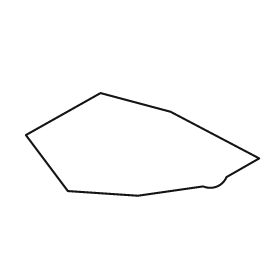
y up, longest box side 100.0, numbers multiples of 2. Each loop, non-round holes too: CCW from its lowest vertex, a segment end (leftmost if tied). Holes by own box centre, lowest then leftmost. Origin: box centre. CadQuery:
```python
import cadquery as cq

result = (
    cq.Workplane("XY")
    .moveTo(-2.0, -22.0)
    .lineTo(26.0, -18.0)
    .threePointArc((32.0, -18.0), (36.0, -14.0))
    .lineTo(50.0, -6.0)
    .lineTo(12.0, 14.0)
    .lineTo(-18.0, 22.0)
    .lineTo(-50.0, 4.0)
    .lineTo(-32.0, -20.0)
    .close()
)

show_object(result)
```